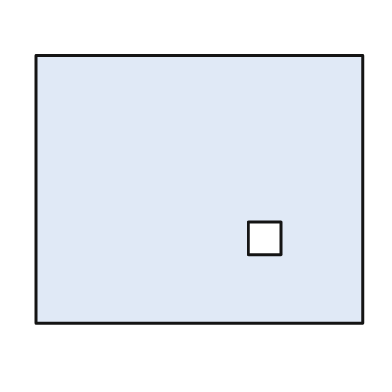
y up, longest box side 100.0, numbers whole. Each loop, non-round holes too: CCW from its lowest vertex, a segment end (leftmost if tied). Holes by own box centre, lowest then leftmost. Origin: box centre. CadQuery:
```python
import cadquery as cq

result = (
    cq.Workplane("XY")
    .moveTo(-50.0, -41.0)
    .lineTo(50.0, -41.0)
    .lineTo(50.0, 41.0)
    .lineTo(-50.0, 41.0)
    .close()
    .moveTo(15.0, -20.0)
    .lineTo(25.0, -20.0)
    .lineTo(25.0, -10.0)
    .lineTo(15.0, -10.0)
    .close()
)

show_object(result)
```